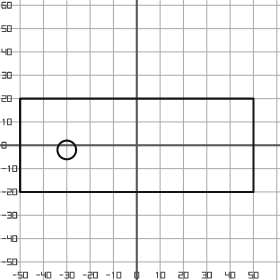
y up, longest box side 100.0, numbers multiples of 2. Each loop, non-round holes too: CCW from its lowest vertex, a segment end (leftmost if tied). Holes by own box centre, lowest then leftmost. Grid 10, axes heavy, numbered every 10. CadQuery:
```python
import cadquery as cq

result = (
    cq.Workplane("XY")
    .moveTo(-50.0, -20.0)
    .lineTo(50.0, -20.0)
    .lineTo(50.0, 20.0)
    .lineTo(-50.0, 20.0)
    .close()
    .moveTo(-30.0, -2.0)
    .circle(4.0)
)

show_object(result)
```